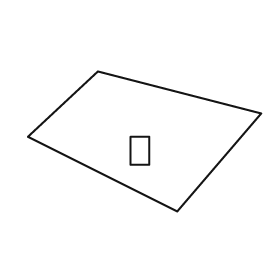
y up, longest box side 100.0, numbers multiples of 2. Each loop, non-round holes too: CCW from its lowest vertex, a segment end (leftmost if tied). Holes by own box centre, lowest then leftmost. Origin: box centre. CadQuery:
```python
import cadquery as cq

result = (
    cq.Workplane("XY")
    .moveTo(14.0, -30.0)
    .lineTo(50.0, 12.0)
    .lineTo(-20.0, 30.0)
    .lineTo(-50.0, 2.0)
    .close()
    .moveTo(-6.0, -10.0)
    .lineTo(2.0, -10.0)
    .lineTo(2.0, 2.0)
    .lineTo(-6.0, 2.0)
    .close()
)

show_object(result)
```